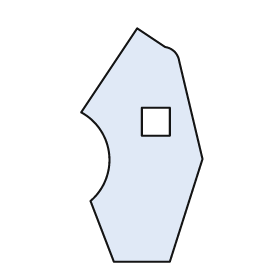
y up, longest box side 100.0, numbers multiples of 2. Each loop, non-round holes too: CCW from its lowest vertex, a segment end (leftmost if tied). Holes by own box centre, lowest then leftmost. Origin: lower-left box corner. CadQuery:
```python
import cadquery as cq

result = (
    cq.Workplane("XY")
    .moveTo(14.0, 0.0)
    .lineTo(38.0, 0.0)
    .lineTo(52.0, 44.0)
    .lineTo(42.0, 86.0)
    .threePointArc((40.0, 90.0), (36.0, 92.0))
    .lineTo(24.0, 100.0)
    .lineTo(0.0, 64.0)
    .threePointArc((12.0, 46.0), (4.0, 26.0))
    .close()
    .moveTo(26.0, 54.0)
    .lineTo(38.0, 54.0)
    .lineTo(38.0, 66.0)
    .lineTo(26.0, 66.0)
    .close()
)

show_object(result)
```